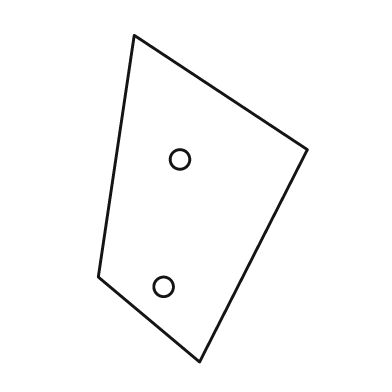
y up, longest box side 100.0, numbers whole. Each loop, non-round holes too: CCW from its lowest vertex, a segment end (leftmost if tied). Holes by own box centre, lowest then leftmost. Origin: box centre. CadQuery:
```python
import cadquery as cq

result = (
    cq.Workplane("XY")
    .moveTo(-1.0, -50.0)
    .lineTo(32.0, 15.0)
    .lineTo(-21.0, 50.0)
    .lineTo(-32.0, -24.0)
    .close()
    .moveTo(-12.0, -27.0)
    .circle(3.0)
    .moveTo(-7.0, 12.0)
    .circle(3.0)
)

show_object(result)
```